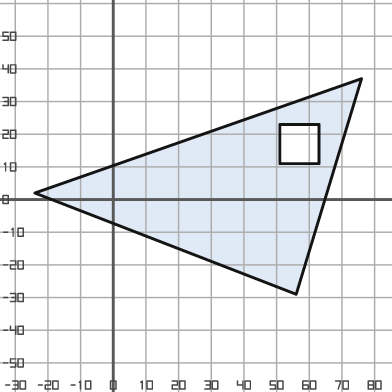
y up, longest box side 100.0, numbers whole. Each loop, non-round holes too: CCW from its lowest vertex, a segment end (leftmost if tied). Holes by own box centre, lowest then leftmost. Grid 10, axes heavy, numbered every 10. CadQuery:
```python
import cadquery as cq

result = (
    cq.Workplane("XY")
    .moveTo(56.0, -29.0)
    .lineTo(76.0, 37.0)
    .lineTo(-24.0, 2.0)
    .close()
    .moveTo(51.0, 11.0)
    .lineTo(63.0, 11.0)
    .lineTo(63.0, 23.0)
    .lineTo(51.0, 23.0)
    .close()
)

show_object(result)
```